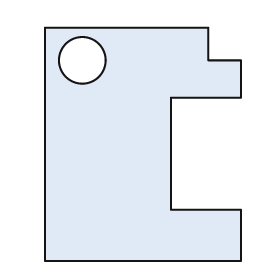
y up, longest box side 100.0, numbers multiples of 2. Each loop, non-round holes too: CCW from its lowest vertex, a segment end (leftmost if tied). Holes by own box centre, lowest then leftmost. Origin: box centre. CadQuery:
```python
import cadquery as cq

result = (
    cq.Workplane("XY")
    .moveTo(-42.0, -50.0)
    .lineTo(42.0, -50.0)
    .lineTo(42.0, -28.0)
    .lineTo(12.0, -28.0)
    .lineTo(12.0, 20.0)
    .lineTo(42.0, 20.0)
    .lineTo(42.0, 36.0)
    .lineTo(28.0, 36.0)
    .lineTo(28.0, 50.0)
    .lineTo(-42.0, 50.0)
    .close()
    .moveTo(-26.0, 36.0)
    .circle(10.0)
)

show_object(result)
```